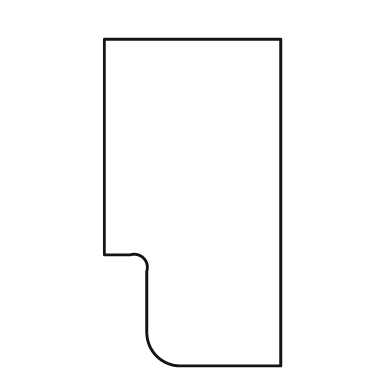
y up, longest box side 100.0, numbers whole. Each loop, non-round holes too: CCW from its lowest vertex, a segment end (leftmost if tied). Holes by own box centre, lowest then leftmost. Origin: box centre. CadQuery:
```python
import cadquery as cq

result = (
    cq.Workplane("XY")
    .moveTo(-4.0, -50.0)
    .lineTo(27.0, -50.0)
    .lineTo(27.0, 50.0)
    .lineTo(-27.0, 50.0)
    .lineTo(-27.0, -16.0)
    .lineTo(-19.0, -16.0)
    .threePointArc((-15.0, -17.0), (-14.0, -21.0))
    .lineTo(-14.0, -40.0)
    .threePointArc((-11.0, -47.0), (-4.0, -50.0))
    .close()
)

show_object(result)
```